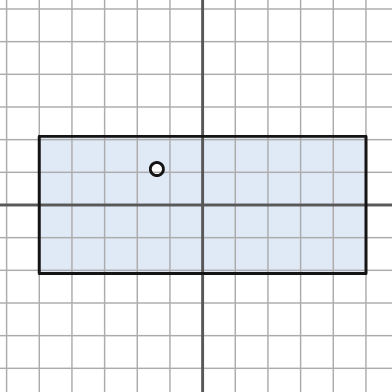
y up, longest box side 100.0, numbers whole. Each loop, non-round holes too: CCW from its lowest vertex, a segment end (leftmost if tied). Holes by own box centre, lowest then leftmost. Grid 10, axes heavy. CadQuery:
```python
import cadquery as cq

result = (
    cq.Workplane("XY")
    .moveTo(-50.0, -21.0)
    .lineTo(50.0, -21.0)
    .lineTo(50.0, 21.0)
    .lineTo(-50.0, 21.0)
    .close()
    .moveTo(-14.0, 11.0)
    .circle(2.0)
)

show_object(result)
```